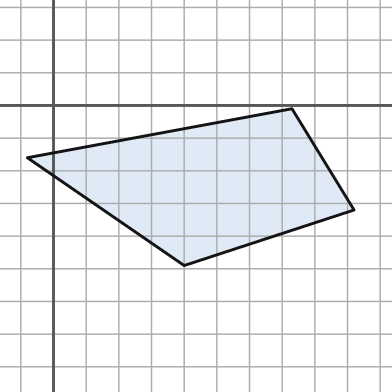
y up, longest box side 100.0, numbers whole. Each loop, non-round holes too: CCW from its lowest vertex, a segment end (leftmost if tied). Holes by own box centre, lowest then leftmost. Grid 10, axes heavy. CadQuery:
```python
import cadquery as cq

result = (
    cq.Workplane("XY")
    .moveTo(40.0, -49.0)
    .lineTo(92.0, -32.0)
    .lineTo(73.0, -1.0)
    .lineTo(-8.0, -16.0)
    .close()
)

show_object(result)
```